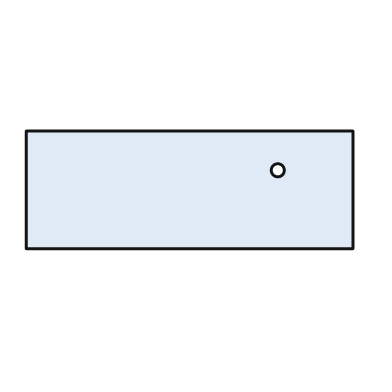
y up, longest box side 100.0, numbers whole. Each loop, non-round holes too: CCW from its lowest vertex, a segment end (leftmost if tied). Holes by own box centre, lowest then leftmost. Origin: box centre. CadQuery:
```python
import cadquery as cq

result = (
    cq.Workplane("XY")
    .moveTo(-50.0, -18.0)
    .lineTo(50.0, -18.0)
    .lineTo(50.0, 18.0)
    .lineTo(-50.0, 18.0)
    .close()
    .moveTo(27.0, 6.0)
    .circle(2.0)
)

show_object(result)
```